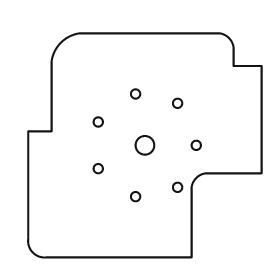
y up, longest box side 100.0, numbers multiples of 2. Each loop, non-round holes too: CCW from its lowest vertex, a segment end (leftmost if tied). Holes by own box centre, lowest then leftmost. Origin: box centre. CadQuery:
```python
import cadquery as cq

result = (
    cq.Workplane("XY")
    .moveTo(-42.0, -48.0)
    .lineTo(20.0, -48.0)
    .lineTo(20.0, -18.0)
    .threePointArc((22.0, -14.0), (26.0, -12.0))
    .lineTo(50.0, -12.0)
    .lineTo(50.0, 34.0)
    .lineTo(38.0, 34.0)
    .lineTo(38.0, 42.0)
    .threePointArc((36.0, 46.0), (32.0, 48.0))
    .lineTo(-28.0, 48.0)
    .threePointArc((-36.0, 44.0), (-40.0, 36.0))
    .lineTo(-40.0, 6.0)
    .lineTo(-50.0, 6.0)
    .lineTo(-50.0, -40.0)
    .threePointArc((-48.0, -46.0), (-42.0, -48.0))
    .close()
    .moveTo(-4.0, -22.0)
    .circle(2.0)
    .moveTo(14.0, -18.0)
    .circle(2.0)
    .moveTo(-20.0, -10.0)
    .circle(2.0)
    .moveTo(0.0, 0.0)
    .circle(4.0)
    .moveTo(22.0, 0.0)
    .circle(2.0)
    .moveTo(-20.0, 10.0)
    .circle(2.0)
    .moveTo(14.0, 18.0)
    .circle(2.0)
    .moveTo(-4.0, 22.0)
    .circle(2.0)
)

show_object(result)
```